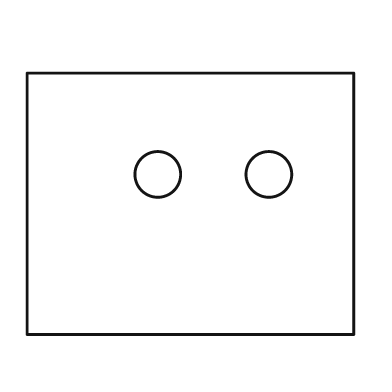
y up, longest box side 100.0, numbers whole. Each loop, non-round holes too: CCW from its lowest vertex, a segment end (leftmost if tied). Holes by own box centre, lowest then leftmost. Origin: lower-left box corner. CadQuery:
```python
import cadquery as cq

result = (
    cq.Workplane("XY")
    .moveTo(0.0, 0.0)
    .lineTo(100.0, 0.0)
    .lineTo(100.0, 80.0)
    .lineTo(0.0, 80.0)
    .close()
    .moveTo(40.0, 49.0)
    .circle(7.0)
    .moveTo(74.0, 49.0)
    .circle(7.0)
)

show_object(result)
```